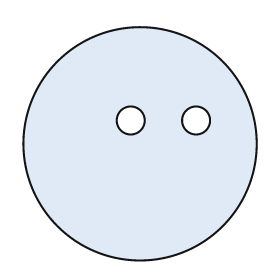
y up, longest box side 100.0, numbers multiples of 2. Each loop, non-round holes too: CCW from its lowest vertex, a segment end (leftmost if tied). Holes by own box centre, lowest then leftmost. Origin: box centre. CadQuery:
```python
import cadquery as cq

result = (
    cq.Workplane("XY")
    .moveTo(0.0, 0.0)
    .circle(50.0)
    .moveTo(-4.0, 10.0)
    .circle(6.0)
    .moveTo(24.0, 10.0)
    .circle(6.0)
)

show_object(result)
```